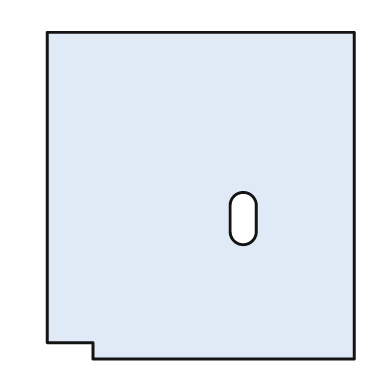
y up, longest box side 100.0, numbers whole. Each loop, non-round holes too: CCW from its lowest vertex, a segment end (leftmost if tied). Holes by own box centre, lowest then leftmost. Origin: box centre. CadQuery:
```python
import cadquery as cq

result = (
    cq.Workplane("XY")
    .moveTo(-33.0, -50.0)
    .lineTo(47.0, -50.0)
    .lineTo(47.0, 50.0)
    .lineTo(-47.0, 50.0)
    .lineTo(-47.0, -45.0)
    .lineTo(-33.0, -45.0)
    .close()
    .moveTo(9.0, -11.0)
    .threePointArc((13.0, -15.0), (17.0, -11.0))
    .lineTo(17.0, -3.0)
    .threePointArc((13.0, 1.0), (9.0, -3.0))
    .close()
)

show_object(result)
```